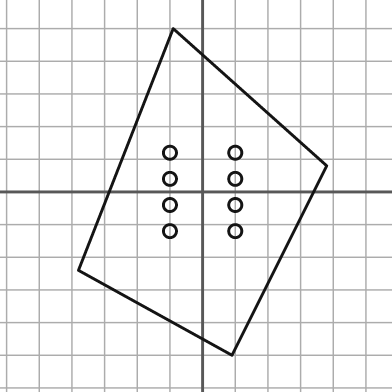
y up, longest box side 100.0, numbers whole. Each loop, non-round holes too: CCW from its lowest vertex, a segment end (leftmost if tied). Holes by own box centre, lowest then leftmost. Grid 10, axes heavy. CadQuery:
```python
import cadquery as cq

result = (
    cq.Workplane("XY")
    .moveTo(9.0, -50.0)
    .lineTo(38.0, 8.0)
    .lineTo(-9.0, 50.0)
    .lineTo(-38.0, -24.0)
    .close()
    .moveTo(-10.0, -12.0)
    .circle(2.0)
    .moveTo(10.0, -12.0)
    .circle(2.0)
    .moveTo(-10.0, -4.0)
    .circle(2.0)
    .moveTo(10.0, -4.0)
    .circle(2.0)
    .moveTo(-10.0, 4.0)
    .circle(2.0)
    .moveTo(10.0, 4.0)
    .circle(2.0)
    .moveTo(-10.0, 12.0)
    .circle(2.0)
    .moveTo(10.0, 12.0)
    .circle(2.0)
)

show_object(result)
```